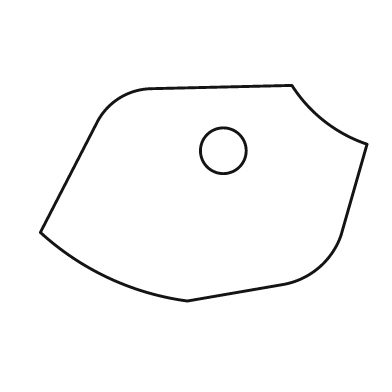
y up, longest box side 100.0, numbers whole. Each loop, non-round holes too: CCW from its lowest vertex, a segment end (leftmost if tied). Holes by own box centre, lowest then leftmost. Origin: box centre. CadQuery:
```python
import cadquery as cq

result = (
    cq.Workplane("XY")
    .moveTo(-5.0, -33.0)
    .lineTo(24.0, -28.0)
    .threePointArc((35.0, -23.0), (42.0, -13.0))
    .lineTo(50.0, 15.0)
    .threePointArc((37.0, 22.0), (27.0, 33.0))
    .lineTo(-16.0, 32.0)
    .threePointArc((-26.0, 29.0), (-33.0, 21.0))
    .lineTo(-50.0, -12.0)
    .threePointArc((-29.0, -26.0), (-5.0, -33.0))
    .close()
    .moveTo(6.0, 13.0)
    .circle(7.0)
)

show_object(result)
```